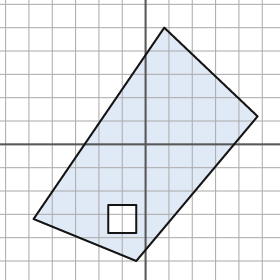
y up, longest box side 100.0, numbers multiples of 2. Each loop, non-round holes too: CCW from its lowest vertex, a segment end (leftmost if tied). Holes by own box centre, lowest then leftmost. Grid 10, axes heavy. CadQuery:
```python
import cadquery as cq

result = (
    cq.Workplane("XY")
    .moveTo(-4.0, -50.0)
    .lineTo(48.0, 12.0)
    .lineTo(8.0, 50.0)
    .lineTo(-48.0, -32.0)
    .close()
    .moveTo(-16.0, -38.0)
    .lineTo(-4.0, -38.0)
    .lineTo(-4.0, -26.0)
    .lineTo(-16.0, -26.0)
    .close()
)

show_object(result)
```